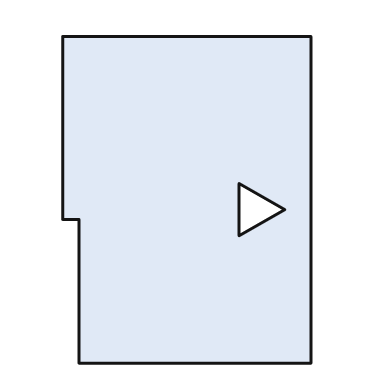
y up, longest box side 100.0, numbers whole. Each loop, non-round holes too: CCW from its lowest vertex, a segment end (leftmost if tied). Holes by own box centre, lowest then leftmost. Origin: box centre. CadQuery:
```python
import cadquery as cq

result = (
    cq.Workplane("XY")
    .moveTo(-33.0, -50.0)
    .lineTo(38.0, -50.0)
    .lineTo(38.0, 50.0)
    .lineTo(-38.0, 50.0)
    .lineTo(-38.0, -6.0)
    .lineTo(-33.0, -6.0)
    .close()
    .moveTo(16.0, -11.0)
    .lineTo(30.0, -3.0)
    .lineTo(16.0, 5.0)
    .close()
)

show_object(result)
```